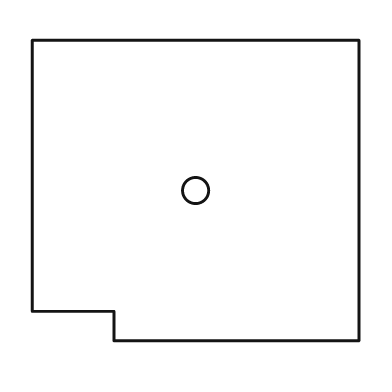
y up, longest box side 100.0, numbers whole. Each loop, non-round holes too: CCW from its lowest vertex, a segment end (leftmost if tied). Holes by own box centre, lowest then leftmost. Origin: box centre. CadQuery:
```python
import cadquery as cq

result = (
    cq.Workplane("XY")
    .moveTo(-25.0, -46.0)
    .lineTo(50.0, -46.0)
    .lineTo(50.0, 46.0)
    .lineTo(-50.0, 46.0)
    .lineTo(-50.0, -37.0)
    .lineTo(-25.0, -37.0)
    .close()
    .moveTo(0.0, 0.0)
    .circle(4.0)
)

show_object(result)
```